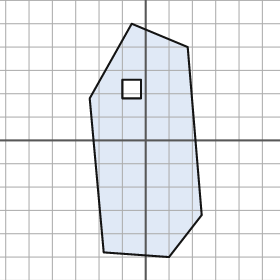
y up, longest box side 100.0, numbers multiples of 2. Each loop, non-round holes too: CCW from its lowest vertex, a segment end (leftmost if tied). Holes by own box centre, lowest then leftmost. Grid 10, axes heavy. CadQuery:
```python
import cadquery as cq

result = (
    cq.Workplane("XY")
    .moveTo(10.0, -50.0)
    .lineTo(24.0, -32.0)
    .lineTo(18.0, 40.0)
    .lineTo(-6.0, 50.0)
    .lineTo(-24.0, 18.0)
    .lineTo(-18.0, -48.0)
    .close()
    .moveTo(-10.0, 18.0)
    .lineTo(-2.0, 18.0)
    .lineTo(-2.0, 26.0)
    .lineTo(-10.0, 26.0)
    .close()
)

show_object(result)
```